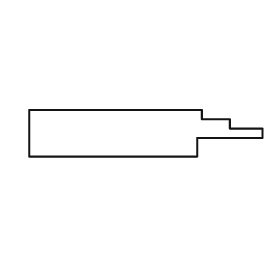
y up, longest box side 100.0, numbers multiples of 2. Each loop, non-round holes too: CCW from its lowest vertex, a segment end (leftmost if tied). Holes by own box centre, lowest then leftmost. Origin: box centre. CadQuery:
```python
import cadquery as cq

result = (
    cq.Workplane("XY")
    .moveTo(-50.0, -10.0)
    .lineTo(22.0, -10.0)
    .lineTo(22.0, -2.0)
    .lineTo(50.0, -2.0)
    .lineTo(50.0, 2.0)
    .lineTo(36.0, 2.0)
    .lineTo(36.0, 6.0)
    .lineTo(24.0, 6.0)
    .lineTo(24.0, 10.0)
    .lineTo(-50.0, 10.0)
    .close()
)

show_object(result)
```